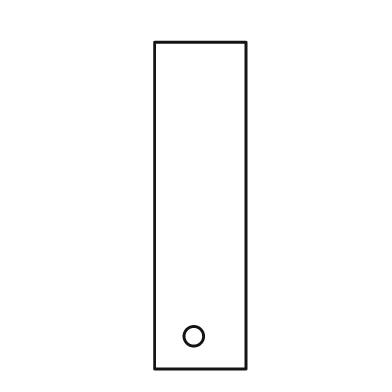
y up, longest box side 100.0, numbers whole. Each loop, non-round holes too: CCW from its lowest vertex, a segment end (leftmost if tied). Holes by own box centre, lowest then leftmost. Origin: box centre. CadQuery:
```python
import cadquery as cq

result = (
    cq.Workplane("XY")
    .moveTo(-14.0, -50.0)
    .lineTo(14.0, -50.0)
    .lineTo(14.0, 50.0)
    .lineTo(-14.0, 50.0)
    .close()
    .moveTo(-2.0, -40.0)
    .circle(3.0)
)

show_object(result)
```